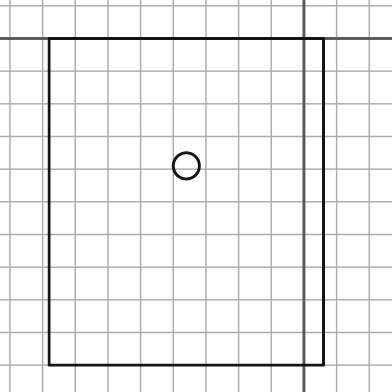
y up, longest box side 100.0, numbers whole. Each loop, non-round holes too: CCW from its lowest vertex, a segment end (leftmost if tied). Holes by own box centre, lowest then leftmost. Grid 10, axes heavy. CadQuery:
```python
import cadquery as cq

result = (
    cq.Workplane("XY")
    .moveTo(-78.0, -100.0)
    .lineTo(6.0, -100.0)
    .lineTo(6.0, 0.0)
    .lineTo(-78.0, 0.0)
    .close()
    .moveTo(-36.0, -39.0)
    .circle(4.0)
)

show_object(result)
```